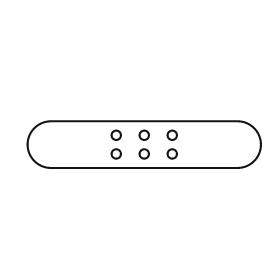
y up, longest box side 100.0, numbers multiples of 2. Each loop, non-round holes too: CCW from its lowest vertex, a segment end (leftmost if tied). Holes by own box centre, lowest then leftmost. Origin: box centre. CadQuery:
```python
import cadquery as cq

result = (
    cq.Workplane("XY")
    .moveTo(-40.0, -10.0)
    .lineTo(40.0, -10.0)
    .threePointArc((50.0, 0.0), (40.0, 10.0))
    .lineTo(-40.0, 10.0)
    .threePointArc((-50.0, 0.0), (-40.0, -10.0))
    .close()
    .moveTo(-12.0, -4.0)
    .circle(2.0)
    .moveTo(0.0, -4.0)
    .circle(2.0)
    .moveTo(12.0, -4.0)
    .circle(2.0)
    .moveTo(-12.0, 4.0)
    .circle(2.0)
    .moveTo(0.0, 4.0)
    .circle(2.0)
    .moveTo(12.0, 4.0)
    .circle(2.0)
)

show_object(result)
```